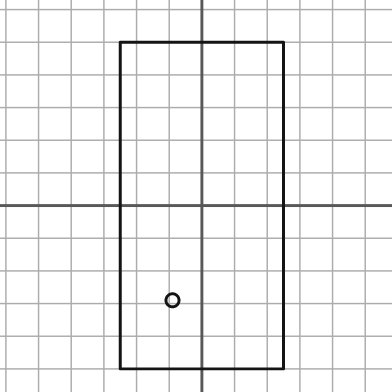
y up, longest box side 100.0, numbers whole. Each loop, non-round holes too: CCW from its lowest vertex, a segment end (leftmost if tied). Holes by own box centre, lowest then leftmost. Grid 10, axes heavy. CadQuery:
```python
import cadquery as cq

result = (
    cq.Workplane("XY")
    .moveTo(-25.0, -50.0)
    .lineTo(25.0, -50.0)
    .lineTo(25.0, 50.0)
    .lineTo(-25.0, 50.0)
    .close()
    .moveTo(-9.0, -29.0)
    .circle(2.0)
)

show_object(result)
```